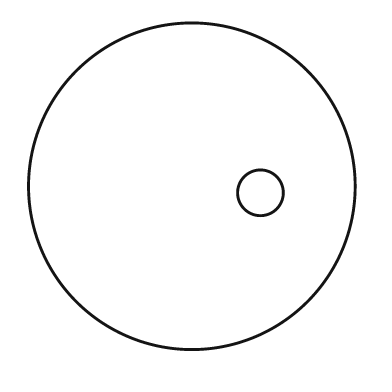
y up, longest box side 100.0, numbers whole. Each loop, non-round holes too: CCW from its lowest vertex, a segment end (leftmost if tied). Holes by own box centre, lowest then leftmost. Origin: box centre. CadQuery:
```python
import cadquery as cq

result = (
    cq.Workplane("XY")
    .moveTo(0.0, 0.0)
    .circle(50.0)
    .moveTo(21.0, -2.0)
    .circle(7.0)
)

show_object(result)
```